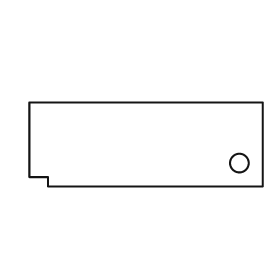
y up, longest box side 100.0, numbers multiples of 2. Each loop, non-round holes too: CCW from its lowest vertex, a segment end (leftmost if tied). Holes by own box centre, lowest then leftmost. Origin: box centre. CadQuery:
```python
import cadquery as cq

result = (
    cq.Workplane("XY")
    .moveTo(-42.0, -18.0)
    .lineTo(50.0, -18.0)
    .lineTo(50.0, 18.0)
    .lineTo(-50.0, 18.0)
    .lineTo(-50.0, -14.0)
    .lineTo(-42.0, -14.0)
    .close()
    .moveTo(40.0, -8.0)
    .circle(4.0)
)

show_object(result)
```